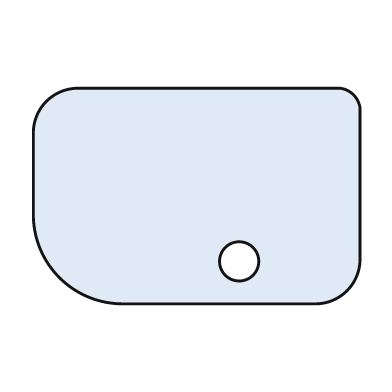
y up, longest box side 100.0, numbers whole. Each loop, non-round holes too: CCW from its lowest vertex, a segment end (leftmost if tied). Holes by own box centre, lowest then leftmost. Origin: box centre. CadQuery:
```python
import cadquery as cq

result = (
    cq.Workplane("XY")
    .moveTo(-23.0, -33.0)
    .lineTo(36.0, -33.0)
    .threePointArc((46.0, -29.0), (50.0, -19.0))
    .lineTo(50.0, 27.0)
    .threePointArc((48.0, 31.0), (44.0, 33.0))
    .lineTo(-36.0, 33.0)
    .threePointArc((-46.0, 29.0), (-50.0, 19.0))
    .lineTo(-50.0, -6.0)
    .threePointArc((-42.0, -25.0), (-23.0, -33.0))
    .close()
    .moveTo(13.0, -20.0)
    .circle(6.0)
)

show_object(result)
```